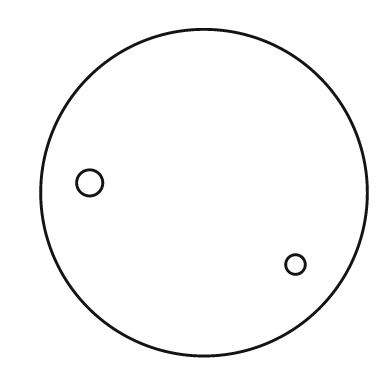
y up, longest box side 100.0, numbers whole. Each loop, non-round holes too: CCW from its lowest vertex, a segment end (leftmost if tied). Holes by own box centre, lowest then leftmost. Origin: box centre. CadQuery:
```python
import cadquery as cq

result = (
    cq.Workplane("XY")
    .moveTo(0.0, 0.0)
    .circle(50.0)
    .moveTo(28.0, -22.0)
    .circle(3.0)
    .moveTo(-35.0, 3.0)
    .circle(4.0)
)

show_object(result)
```